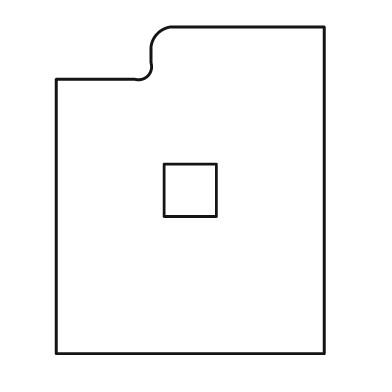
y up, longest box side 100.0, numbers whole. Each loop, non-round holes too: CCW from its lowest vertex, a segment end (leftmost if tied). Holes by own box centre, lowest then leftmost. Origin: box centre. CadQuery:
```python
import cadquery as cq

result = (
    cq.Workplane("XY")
    .moveTo(-41.0, -50.0)
    .lineTo(41.0, -50.0)
    .lineTo(41.0, 50.0)
    .lineTo(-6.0, 50.0)
    .threePointArc((-10.0, 48.0), (-12.0, 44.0))
    .lineTo(-12.0, 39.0)
    .threePointArc((-13.0, 35.0), (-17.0, 34.0))
    .lineTo(-41.0, 34.0)
    .close()
    .moveTo(-8.0, -8.0)
    .lineTo(8.0, -8.0)
    .lineTo(8.0, 8.0)
    .lineTo(-8.0, 8.0)
    .close()
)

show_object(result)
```